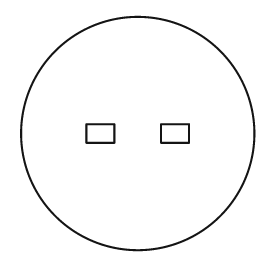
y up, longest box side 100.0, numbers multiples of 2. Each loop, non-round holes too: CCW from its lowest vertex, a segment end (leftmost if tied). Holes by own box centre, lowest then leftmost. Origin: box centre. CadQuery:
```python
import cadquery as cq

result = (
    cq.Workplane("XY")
    .moveTo(0.0, 0.0)
    .circle(50.0)
    .moveTo(-22.0, -4.0)
    .lineTo(-10.0, -4.0)
    .lineTo(-10.0, 4.0)
    .lineTo(-22.0, 4.0)
    .close()
    .moveTo(10.0, -4.0)
    .lineTo(22.0, -4.0)
    .lineTo(22.0, 4.0)
    .lineTo(10.0, 4.0)
    .close()
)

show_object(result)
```